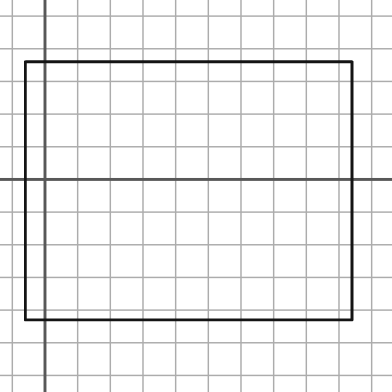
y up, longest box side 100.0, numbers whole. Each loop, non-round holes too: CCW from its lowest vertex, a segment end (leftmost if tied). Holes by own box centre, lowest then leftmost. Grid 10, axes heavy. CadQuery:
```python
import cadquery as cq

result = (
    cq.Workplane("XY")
    .moveTo(-6.0, -43.0)
    .lineTo(94.0, -43.0)
    .lineTo(94.0, 36.0)
    .lineTo(-6.0, 36.0)
    .close()
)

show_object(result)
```